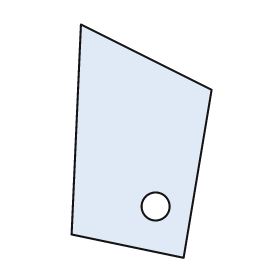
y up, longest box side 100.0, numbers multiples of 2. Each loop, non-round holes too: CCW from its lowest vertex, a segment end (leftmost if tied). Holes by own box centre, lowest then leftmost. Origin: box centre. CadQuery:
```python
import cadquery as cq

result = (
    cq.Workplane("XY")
    .moveTo(18.0, -50.0)
    .lineTo(30.0, 22.0)
    .lineTo(-26.0, 50.0)
    .lineTo(-30.0, -40.0)
    .close()
    .moveTo(6.0, -28.0)
    .circle(6.0)
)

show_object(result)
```